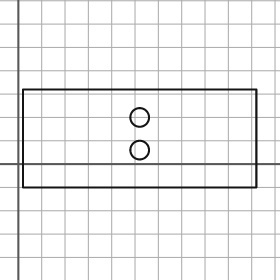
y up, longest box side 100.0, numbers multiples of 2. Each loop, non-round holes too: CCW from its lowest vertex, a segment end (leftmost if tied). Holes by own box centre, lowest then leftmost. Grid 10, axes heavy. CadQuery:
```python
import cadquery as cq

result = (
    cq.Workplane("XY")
    .moveTo(2.0, -10.0)
    .lineTo(102.0, -10.0)
    .lineTo(102.0, 32.0)
    .lineTo(2.0, 32.0)
    .close()
    .moveTo(52.0, 6.0)
    .circle(4.0)
    .moveTo(52.0, 20.0)
    .circle(4.0)
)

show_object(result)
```